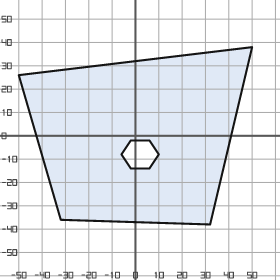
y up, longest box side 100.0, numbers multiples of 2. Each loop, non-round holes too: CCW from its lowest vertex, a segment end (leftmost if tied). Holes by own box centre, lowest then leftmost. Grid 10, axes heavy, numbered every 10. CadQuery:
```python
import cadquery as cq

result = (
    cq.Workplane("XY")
    .moveTo(32.0, -38.0)
    .lineTo(50.0, 38.0)
    .lineTo(-50.0, 26.0)
    .lineTo(-32.0, -36.0)
    .close()
    .moveTo(-2.0, -14.0)
    .lineTo(6.0, -14.0)
    .lineTo(10.0, -8.0)
    .lineTo(6.0, -2.0)
    .lineTo(-2.0, -2.0)
    .lineTo(-6.0, -8.0)
    .close()
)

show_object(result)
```